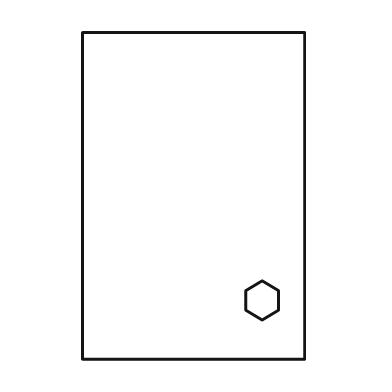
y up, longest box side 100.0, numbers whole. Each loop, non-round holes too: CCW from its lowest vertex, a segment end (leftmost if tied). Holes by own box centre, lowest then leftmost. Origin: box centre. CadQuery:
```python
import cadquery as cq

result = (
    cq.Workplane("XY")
    .moveTo(-34.0, -50.0)
    .lineTo(34.0, -50.0)
    .lineTo(34.0, 50.0)
    .lineTo(-34.0, 50.0)
    .close()
    .moveTo(21.0, -38.0)
    .lineTo(26.0, -35.0)
    .lineTo(26.0, -29.0)
    .lineTo(21.0, -26.0)
    .lineTo(16.0, -29.0)
    .lineTo(16.0, -35.0)
    .close()
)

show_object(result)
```